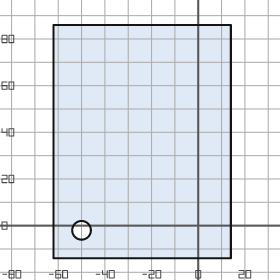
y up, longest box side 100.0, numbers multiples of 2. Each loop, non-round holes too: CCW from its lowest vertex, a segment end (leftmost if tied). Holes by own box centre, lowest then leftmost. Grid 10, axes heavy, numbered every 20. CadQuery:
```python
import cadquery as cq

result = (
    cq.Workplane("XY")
    .moveTo(-62.0, -14.0)
    .lineTo(14.0, -14.0)
    .lineTo(14.0, 86.0)
    .lineTo(-62.0, 86.0)
    .close()
    .moveTo(-50.0, -2.0)
    .circle(4.0)
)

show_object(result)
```